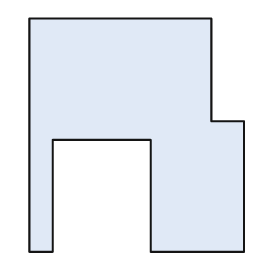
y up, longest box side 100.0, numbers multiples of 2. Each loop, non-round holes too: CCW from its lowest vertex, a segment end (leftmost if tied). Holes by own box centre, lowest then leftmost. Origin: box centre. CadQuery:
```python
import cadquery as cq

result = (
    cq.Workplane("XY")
    .moveTo(-46.0, -50.0)
    .lineTo(-36.0, -50.0)
    .lineTo(-36.0, -2.0)
    .lineTo(6.0, -2.0)
    .lineTo(6.0, -50.0)
    .lineTo(46.0, -50.0)
    .lineTo(46.0, 6.0)
    .lineTo(32.0, 6.0)
    .lineTo(32.0, 50.0)
    .lineTo(-46.0, 50.0)
    .close()
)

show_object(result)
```